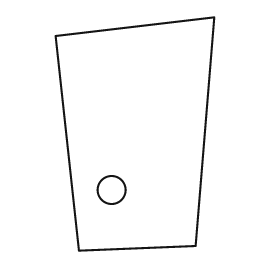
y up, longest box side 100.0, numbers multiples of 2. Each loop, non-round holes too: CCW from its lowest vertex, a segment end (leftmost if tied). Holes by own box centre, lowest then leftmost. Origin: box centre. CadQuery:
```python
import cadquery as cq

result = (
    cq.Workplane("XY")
    .moveTo(-24.0, -50.0)
    .lineTo(26.0, -48.0)
    .lineTo(34.0, 50.0)
    .lineTo(-34.0, 42.0)
    .close()
    .moveTo(-10.0, -24.0)
    .circle(6.0)
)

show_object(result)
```